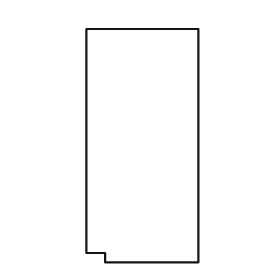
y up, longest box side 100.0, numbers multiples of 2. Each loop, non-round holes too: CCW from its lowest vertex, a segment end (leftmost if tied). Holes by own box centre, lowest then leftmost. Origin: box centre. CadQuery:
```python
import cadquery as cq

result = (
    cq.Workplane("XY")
    .moveTo(-16.0, -50.0)
    .lineTo(24.0, -50.0)
    .lineTo(24.0, 50.0)
    .lineTo(-24.0, 50.0)
    .lineTo(-24.0, -46.0)
    .lineTo(-16.0, -46.0)
    .close()
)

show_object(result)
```